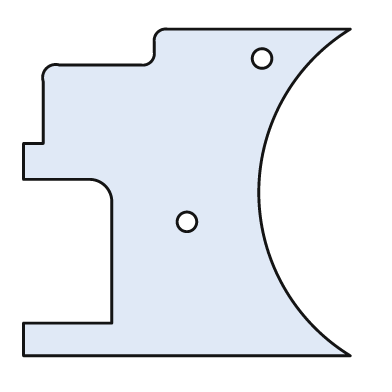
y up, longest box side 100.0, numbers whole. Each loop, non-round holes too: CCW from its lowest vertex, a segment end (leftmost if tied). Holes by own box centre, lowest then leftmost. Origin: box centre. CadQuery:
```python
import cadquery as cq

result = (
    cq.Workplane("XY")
    .moveTo(-50.0, -50.0)
    .lineTo(50.0, -50.0)
    .threePointArc((22.0, 0.0), (50.0, 50.0))
    .lineTo(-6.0, 50.0)
    .threePointArc((-9.0, 49.0), (-10.0, 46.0))
    .lineTo(-10.0, 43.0)
    .threePointArc((-11.0, 40.0), (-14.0, 39.0))
    .lineTo(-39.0, 39.0)
    .threePointArc((-43.0, 38.0), (-44.0, 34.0))
    .lineTo(-44.0, 15.0)
    .lineTo(-50.0, 15.0)
    .lineTo(-50.0, 4.0)
    .lineTo(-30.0, 4.0)
    .threePointArc((-25.0, 2.0), (-23.0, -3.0))
    .lineTo(-23.0, -40.0)
    .lineTo(-50.0, -40.0)
    .close()
    .moveTo(0.0, -9.0)
    .circle(3.0)
    .moveTo(23.0, 41.0)
    .circle(3.0)
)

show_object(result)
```